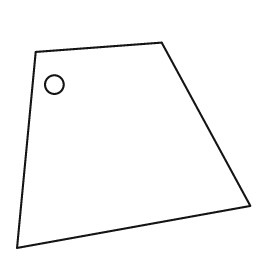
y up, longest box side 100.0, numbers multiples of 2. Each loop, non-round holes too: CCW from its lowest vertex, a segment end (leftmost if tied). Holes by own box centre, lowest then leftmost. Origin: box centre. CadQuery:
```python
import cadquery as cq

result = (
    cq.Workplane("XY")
    .moveTo(-50.0, -44.0)
    .lineTo(50.0, -26.0)
    .lineTo(12.0, 44.0)
    .lineTo(-42.0, 40.0)
    .close()
    .moveTo(-34.0, 26.0)
    .circle(4.0)
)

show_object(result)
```